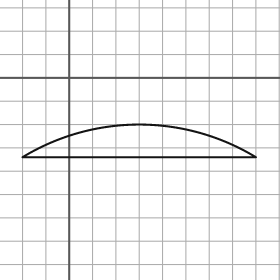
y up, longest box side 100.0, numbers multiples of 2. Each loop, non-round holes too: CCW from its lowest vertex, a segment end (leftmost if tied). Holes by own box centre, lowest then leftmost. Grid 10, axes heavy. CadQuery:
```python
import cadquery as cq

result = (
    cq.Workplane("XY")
    .moveTo(-20.0, -34.0)
    .lineTo(80.0, -34.0)
    .threePointArc((30.0, -20.0), (-20.0, -34.0))
    .close()
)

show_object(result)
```